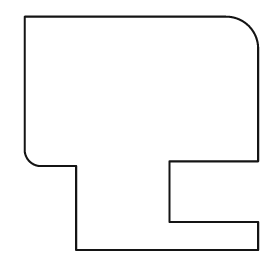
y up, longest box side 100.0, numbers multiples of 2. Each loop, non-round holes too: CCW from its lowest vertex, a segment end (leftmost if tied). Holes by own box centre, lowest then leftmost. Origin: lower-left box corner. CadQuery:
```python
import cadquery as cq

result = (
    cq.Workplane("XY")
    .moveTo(22.0, 0.0)
    .lineTo(100.0, 0.0)
    .lineTo(100.0, 12.0)
    .lineTo(62.0, 12.0)
    .lineTo(62.0, 38.0)
    .lineTo(100.0, 38.0)
    .lineTo(100.0, 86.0)
    .threePointArc((96.0, 96.0), (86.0, 100.0))
    .lineTo(0.0, 100.0)
    .lineTo(0.0, 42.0)
    .threePointArc((2.0, 38.0), (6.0, 36.0))
    .lineTo(22.0, 36.0)
    .close()
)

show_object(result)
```